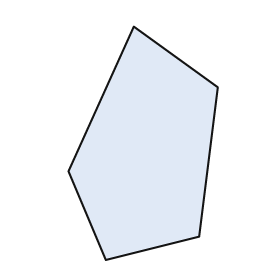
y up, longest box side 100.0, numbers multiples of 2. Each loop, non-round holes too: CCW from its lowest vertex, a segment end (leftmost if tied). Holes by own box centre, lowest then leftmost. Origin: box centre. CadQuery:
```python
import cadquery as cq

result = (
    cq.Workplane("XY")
    .moveTo(-16.0, -50.0)
    .lineTo(24.0, -40.0)
    .lineTo(32.0, 24.0)
    .lineTo(-4.0, 50.0)
    .lineTo(-32.0, -12.0)
    .close()
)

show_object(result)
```